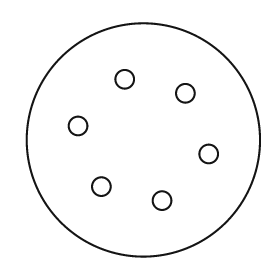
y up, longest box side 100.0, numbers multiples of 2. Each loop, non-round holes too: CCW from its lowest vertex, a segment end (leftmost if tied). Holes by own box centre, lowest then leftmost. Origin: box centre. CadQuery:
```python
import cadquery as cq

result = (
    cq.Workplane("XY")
    .moveTo(0.0, 0.0)
    .circle(50.0)
    .moveTo(8.0, -26.0)
    .circle(4.0)
    .moveTo(-18.0, -20.0)
    .circle(4.0)
    .moveTo(28.0, -6.0)
    .circle(4.0)
    .moveTo(-28.0, 6.0)
    .circle(4.0)
    .moveTo(18.0, 20.0)
    .circle(4.0)
    .moveTo(-8.0, 26.0)
    .circle(4.0)
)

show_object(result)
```